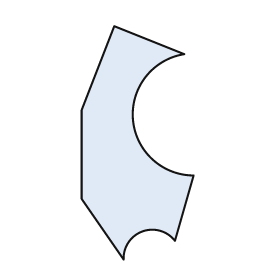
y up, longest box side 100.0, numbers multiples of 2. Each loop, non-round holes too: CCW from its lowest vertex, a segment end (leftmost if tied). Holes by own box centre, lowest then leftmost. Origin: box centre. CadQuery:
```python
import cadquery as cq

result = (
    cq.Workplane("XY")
    .moveTo(-6.0, -50.0)
    .threePointArc((2.0, -38.0), (16.0, -42.0))
    .lineTo(24.0, -14.0)
    .threePointArc((-2.0, 10.0), (20.0, 38.0))
    .lineTo(-10.0, 50.0)
    .lineTo(-24.0, 14.0)
    .lineTo(-24.0, -24.0)
    .close()
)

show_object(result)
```